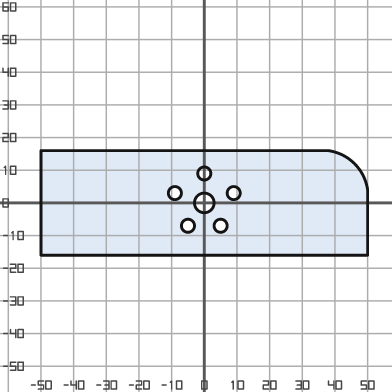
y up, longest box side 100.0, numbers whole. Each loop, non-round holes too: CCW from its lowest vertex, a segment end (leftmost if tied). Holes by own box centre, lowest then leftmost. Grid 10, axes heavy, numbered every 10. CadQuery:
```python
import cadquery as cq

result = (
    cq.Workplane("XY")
    .moveTo(-50.0, -16.0)
    .lineTo(50.0, -16.0)
    .lineTo(50.0, 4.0)
    .threePointArc((46.0, 12.0), (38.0, 16.0))
    .lineTo(-50.0, 16.0)
    .close()
    .moveTo(-5.0, -7.0)
    .circle(2.0)
    .moveTo(5.0, -7.0)
    .circle(2.0)
    .moveTo(0.0, 0.0)
    .circle(3.0)
    .moveTo(-9.0, 3.0)
    .circle(2.0)
    .moveTo(9.0, 3.0)
    .circle(2.0)
    .moveTo(0.0, 9.0)
    .circle(2.0)
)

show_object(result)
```